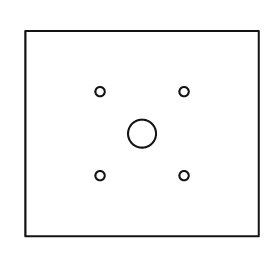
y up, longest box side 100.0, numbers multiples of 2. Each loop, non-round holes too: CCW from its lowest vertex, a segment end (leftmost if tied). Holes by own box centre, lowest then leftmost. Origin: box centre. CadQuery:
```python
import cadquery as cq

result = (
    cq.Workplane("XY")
    .moveTo(-50.0, -44.0)
    .lineTo(50.0, -44.0)
    .lineTo(50.0, 44.0)
    .lineTo(-50.0, 44.0)
    .close()
    .moveTo(-18.0, -18.0)
    .circle(2.0)
    .moveTo(18.0, -18.0)
    .circle(2.0)
    .moveTo(0.0, 0.0)
    .circle(6.0)
    .moveTo(-18.0, 18.0)
    .circle(2.0)
    .moveTo(18.0, 18.0)
    .circle(2.0)
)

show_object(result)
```